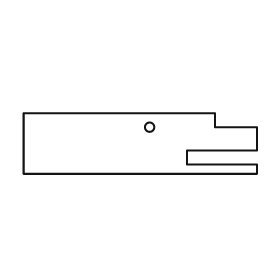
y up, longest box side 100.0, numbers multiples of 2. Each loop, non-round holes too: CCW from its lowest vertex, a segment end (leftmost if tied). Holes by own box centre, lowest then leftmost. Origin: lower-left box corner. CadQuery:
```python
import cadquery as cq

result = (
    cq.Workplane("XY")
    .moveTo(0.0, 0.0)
    .lineTo(100.0, 0.0)
    .lineTo(100.0, 4.0)
    .lineTo(70.0, 4.0)
    .lineTo(70.0, 10.0)
    .lineTo(100.0, 10.0)
    .lineTo(100.0, 20.0)
    .lineTo(82.0, 20.0)
    .lineTo(82.0, 26.0)
    .lineTo(0.0, 26.0)
    .close()
    .moveTo(54.0, 20.0)
    .circle(2.0)
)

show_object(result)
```